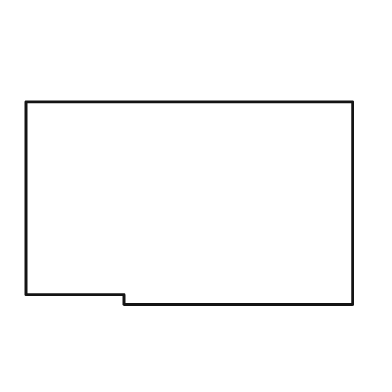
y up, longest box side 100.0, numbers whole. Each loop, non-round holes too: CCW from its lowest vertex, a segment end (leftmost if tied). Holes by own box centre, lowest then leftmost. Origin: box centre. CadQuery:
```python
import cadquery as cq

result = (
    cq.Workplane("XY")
    .moveTo(-20.0, -31.0)
    .lineTo(50.0, -31.0)
    .lineTo(50.0, 31.0)
    .lineTo(-50.0, 31.0)
    .lineTo(-50.0, -28.0)
    .lineTo(-20.0, -28.0)
    .close()
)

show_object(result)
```